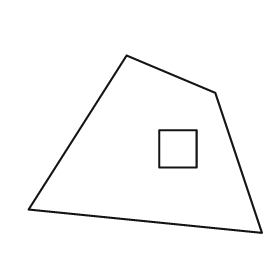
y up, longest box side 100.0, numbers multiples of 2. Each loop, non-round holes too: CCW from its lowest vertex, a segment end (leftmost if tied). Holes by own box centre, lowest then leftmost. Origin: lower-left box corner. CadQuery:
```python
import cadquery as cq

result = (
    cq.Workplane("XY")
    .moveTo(100.0, 0.0)
    .lineTo(80.0, 60.0)
    .lineTo(42.0, 76.0)
    .lineTo(0.0, 10.0)
    .close()
    .moveTo(56.0, 28.0)
    .lineTo(72.0, 28.0)
    .lineTo(72.0, 44.0)
    .lineTo(56.0, 44.0)
    .close()
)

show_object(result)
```